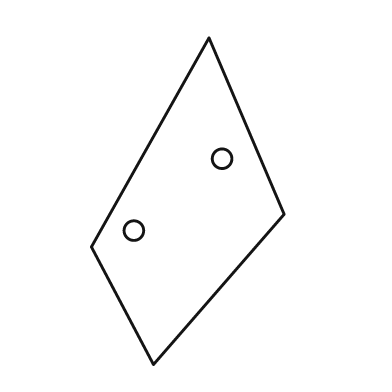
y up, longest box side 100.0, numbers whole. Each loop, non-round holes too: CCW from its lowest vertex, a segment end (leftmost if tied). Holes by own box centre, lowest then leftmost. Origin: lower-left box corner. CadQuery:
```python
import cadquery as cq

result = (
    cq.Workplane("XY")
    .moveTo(19.0, 0.0)
    .lineTo(59.0, 46.0)
    .lineTo(36.0, 100.0)
    .lineTo(0.0, 36.0)
    .close()
    .moveTo(13.0, 41.0)
    .circle(3.0)
    .moveTo(40.0, 63.0)
    .circle(3.0)
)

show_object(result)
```